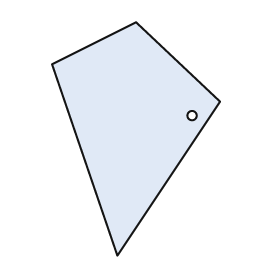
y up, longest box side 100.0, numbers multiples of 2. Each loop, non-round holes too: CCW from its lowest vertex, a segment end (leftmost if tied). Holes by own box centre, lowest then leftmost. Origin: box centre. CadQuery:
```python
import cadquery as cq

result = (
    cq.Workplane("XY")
    .moveTo(-8.0, -50.0)
    .lineTo(36.0, 16.0)
    .lineTo(0.0, 50.0)
    .lineTo(-36.0, 32.0)
    .close()
    .moveTo(24.0, 10.0)
    .circle(2.0)
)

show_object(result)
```